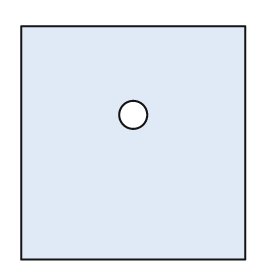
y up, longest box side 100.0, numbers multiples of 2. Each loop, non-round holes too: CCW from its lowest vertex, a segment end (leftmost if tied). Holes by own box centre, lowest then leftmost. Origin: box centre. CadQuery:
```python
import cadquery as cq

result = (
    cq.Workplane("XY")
    .moveTo(-48.0, -50.0)
    .lineTo(48.0, -50.0)
    .lineTo(48.0, 50.0)
    .lineTo(-48.0, 50.0)
    .close()
    .moveTo(0.0, 12.0)
    .circle(6.0)
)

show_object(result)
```